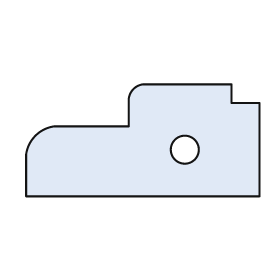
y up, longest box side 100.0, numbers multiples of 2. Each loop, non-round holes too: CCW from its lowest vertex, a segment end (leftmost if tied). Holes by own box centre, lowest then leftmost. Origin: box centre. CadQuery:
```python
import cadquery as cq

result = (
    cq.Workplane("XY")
    .moveTo(-50.0, -24.0)
    .lineTo(50.0, -24.0)
    .lineTo(50.0, 16.0)
    .lineTo(38.0, 16.0)
    .lineTo(38.0, 24.0)
    .lineTo(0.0, 24.0)
    .threePointArc((-4.0, 22.0), (-6.0, 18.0))
    .lineTo(-6.0, 6.0)
    .lineTo(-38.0, 6.0)
    .threePointArc((-46.0, 2.0), (-50.0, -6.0))
    .close()
    .moveTo(18.0, -4.0)
    .circle(6.0)
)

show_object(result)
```